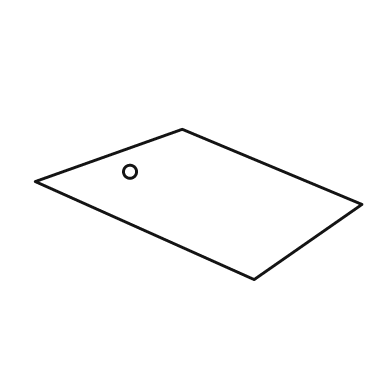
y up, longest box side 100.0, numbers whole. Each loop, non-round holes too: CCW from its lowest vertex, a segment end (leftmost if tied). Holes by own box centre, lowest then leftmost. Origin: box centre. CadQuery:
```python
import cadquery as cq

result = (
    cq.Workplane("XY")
    .moveTo(17.0, -23.0)
    .lineTo(50.0, 0.0)
    .lineTo(-5.0, 23.0)
    .lineTo(-50.0, 7.0)
    .close()
    .moveTo(-21.0, 10.0)
    .circle(2.0)
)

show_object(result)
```